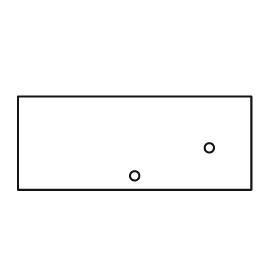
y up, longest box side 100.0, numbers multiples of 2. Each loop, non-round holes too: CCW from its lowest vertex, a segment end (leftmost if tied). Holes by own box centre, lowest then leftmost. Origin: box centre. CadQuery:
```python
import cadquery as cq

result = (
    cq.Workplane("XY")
    .moveTo(-50.0, -20.0)
    .lineTo(50.0, -20.0)
    .lineTo(50.0, 20.0)
    .lineTo(-50.0, 20.0)
    .close()
    .moveTo(0.0, -14.0)
    .circle(2.0)
    .moveTo(32.0, -2.0)
    .circle(2.0)
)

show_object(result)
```